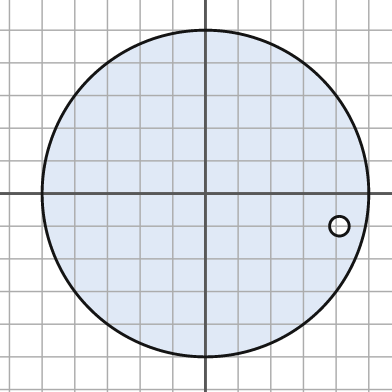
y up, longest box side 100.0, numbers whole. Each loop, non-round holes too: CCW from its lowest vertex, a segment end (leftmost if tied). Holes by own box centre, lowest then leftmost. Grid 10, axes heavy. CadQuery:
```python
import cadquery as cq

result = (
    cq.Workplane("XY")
    .moveTo(0.0, 0.0)
    .circle(50.0)
    .moveTo(41.0, -10.0)
    .circle(3.0)
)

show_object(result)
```